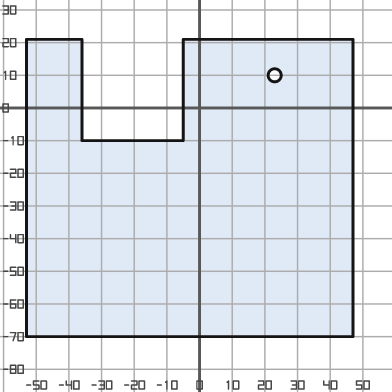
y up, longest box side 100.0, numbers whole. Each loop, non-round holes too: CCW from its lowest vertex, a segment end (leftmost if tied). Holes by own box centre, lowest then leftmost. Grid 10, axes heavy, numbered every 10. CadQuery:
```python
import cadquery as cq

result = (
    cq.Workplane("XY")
    .moveTo(-53.0, -70.0)
    .lineTo(47.0, -70.0)
    .lineTo(47.0, 21.0)
    .lineTo(-5.0, 21.0)
    .lineTo(-5.0, -10.0)
    .lineTo(-36.0, -10.0)
    .lineTo(-36.0, 21.0)
    .lineTo(-53.0, 21.0)
    .close()
    .moveTo(23.0, 10.0)
    .circle(2.0)
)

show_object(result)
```